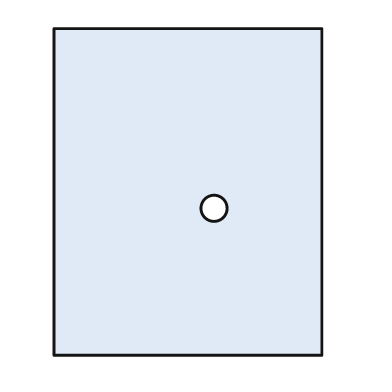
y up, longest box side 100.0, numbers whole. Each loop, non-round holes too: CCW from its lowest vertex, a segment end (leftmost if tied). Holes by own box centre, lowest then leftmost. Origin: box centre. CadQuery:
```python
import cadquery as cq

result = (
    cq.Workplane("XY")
    .moveTo(-41.0, -50.0)
    .lineTo(41.0, -50.0)
    .lineTo(41.0, 50.0)
    .lineTo(-41.0, 50.0)
    .close()
    .moveTo(8.0, -5.0)
    .circle(4.0)
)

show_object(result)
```